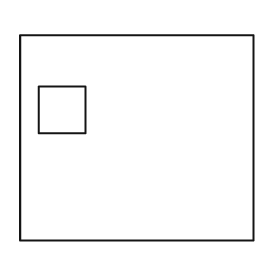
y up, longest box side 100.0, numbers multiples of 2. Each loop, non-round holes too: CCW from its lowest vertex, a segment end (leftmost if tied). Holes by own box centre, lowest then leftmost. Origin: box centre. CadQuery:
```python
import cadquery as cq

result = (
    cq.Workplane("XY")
    .moveTo(-50.0, -44.0)
    .lineTo(50.0, -44.0)
    .lineTo(50.0, 44.0)
    .lineTo(-50.0, 44.0)
    .close()
    .moveTo(-42.0, 2.0)
    .lineTo(-22.0, 2.0)
    .lineTo(-22.0, 22.0)
    .lineTo(-42.0, 22.0)
    .close()
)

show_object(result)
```